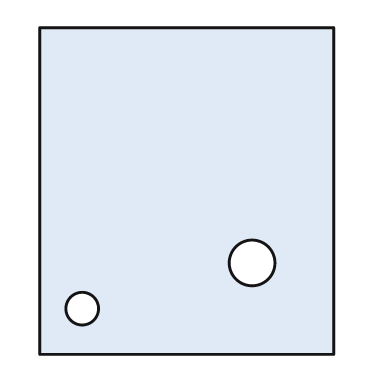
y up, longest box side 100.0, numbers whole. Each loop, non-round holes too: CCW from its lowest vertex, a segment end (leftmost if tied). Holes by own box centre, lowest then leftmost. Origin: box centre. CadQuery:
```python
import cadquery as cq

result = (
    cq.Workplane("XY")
    .moveTo(-45.0, -50.0)
    .lineTo(45.0, -50.0)
    .lineTo(45.0, 50.0)
    .lineTo(-45.0, 50.0)
    .close()
    .moveTo(-32.0, -36.0)
    .circle(5.0)
    .moveTo(20.0, -22.0)
    .circle(7.0)
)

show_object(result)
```